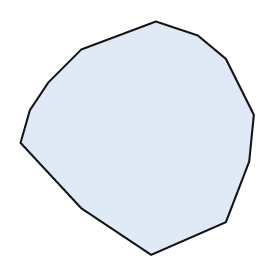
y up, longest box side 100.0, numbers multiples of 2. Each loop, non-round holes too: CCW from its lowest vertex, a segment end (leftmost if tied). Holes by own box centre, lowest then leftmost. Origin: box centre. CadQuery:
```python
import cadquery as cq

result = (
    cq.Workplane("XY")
    .moveTo(6.0, -50.0)
    .lineTo(38.0, -36.0)
    .lineTo(48.0, -10.0)
    .lineTo(50.0, 10.0)
    .lineTo(38.0, 34.0)
    .lineTo(26.0, 44.0)
    .lineTo(8.0, 50.0)
    .lineTo(-24.0, 38.0)
    .lineTo(-38.0, 24.0)
    .lineTo(-46.0, 12.0)
    .lineTo(-50.0, -2.0)
    .lineTo(-24.0, -30.0)
    .close()
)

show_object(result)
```